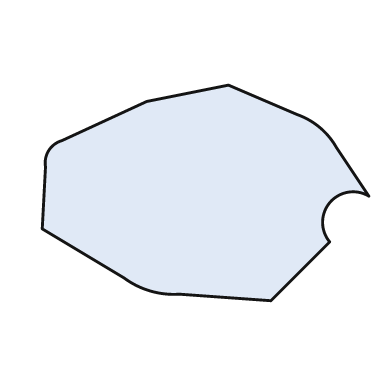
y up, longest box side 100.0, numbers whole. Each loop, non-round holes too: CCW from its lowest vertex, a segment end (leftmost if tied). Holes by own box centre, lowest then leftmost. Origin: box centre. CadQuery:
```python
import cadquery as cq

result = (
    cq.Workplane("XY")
    .moveTo(20.0, -33.0)
    .lineTo(38.0, -15.0)
    .threePointArc((38.0, -3.0), (50.0, -1.0))
    .lineTo(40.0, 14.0)
    .threePointArc((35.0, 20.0), (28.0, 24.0))
    .lineTo(7.0, 33.0)
    .lineTo(-18.0, 28.0)
    .lineTo(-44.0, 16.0)
    .threePointArc((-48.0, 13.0), (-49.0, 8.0))
    .lineTo(-50.0, -11.0)
    .lineTo(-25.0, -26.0)
    .threePointArc((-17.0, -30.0), (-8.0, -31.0))
    .close()
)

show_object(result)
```